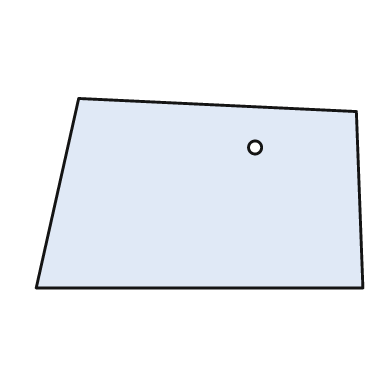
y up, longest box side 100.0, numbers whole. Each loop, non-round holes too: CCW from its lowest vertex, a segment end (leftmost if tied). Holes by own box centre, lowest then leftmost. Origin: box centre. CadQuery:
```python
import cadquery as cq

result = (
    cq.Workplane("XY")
    .moveTo(-50.0, -29.0)
    .lineTo(50.0, -29.0)
    .lineTo(48.0, 25.0)
    .lineTo(-37.0, 29.0)
    .close()
    .moveTo(17.0, 14.0)
    .circle(2.0)
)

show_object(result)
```